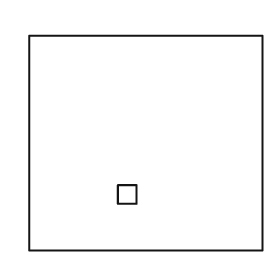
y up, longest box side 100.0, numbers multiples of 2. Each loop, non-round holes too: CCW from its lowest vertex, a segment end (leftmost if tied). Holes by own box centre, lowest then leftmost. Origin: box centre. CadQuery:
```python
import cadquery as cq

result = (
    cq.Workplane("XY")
    .moveTo(-50.0, -46.0)
    .lineTo(50.0, -46.0)
    .lineTo(50.0, 46.0)
    .lineTo(-50.0, 46.0)
    .close()
    .moveTo(-12.0, -26.0)
    .lineTo(-4.0, -26.0)
    .lineTo(-4.0, -18.0)
    .lineTo(-12.0, -18.0)
    .close()
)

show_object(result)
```